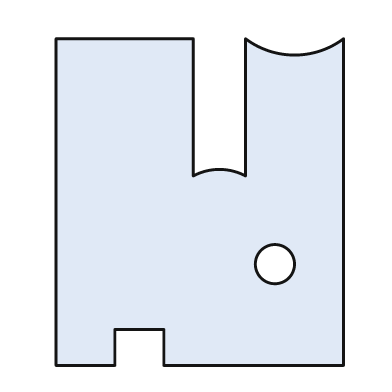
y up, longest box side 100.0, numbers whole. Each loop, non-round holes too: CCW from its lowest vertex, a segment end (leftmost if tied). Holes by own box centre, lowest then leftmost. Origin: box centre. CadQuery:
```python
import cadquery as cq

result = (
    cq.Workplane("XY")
    .moveTo(-44.0, -50.0)
    .lineTo(-26.0, -50.0)
    .lineTo(-26.0, -39.0)
    .lineTo(-11.0, -39.0)
    .lineTo(-11.0, -50.0)
    .lineTo(44.0, -50.0)
    .lineTo(44.0, 50.0)
    .threePointArc((29.0, 45.0), (14.0, 50.0))
    .lineTo(14.0, 8.0)
    .threePointArc((6.0, 10.0), (-2.0, 8.0))
    .lineTo(-2.0, 50.0)
    .lineTo(-44.0, 50.0)
    .close()
    .moveTo(23.0, -19.0)
    .circle(6.0)
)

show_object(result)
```